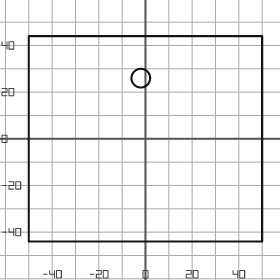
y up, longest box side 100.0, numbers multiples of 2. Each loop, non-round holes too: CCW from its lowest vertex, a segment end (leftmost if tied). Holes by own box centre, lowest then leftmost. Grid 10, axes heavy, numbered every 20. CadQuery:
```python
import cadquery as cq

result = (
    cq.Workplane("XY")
    .moveTo(-50.0, -44.0)
    .lineTo(50.0, -44.0)
    .lineTo(50.0, 44.0)
    .lineTo(-50.0, 44.0)
    .close()
    .moveTo(-2.0, 26.0)
    .circle(4.0)
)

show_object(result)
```